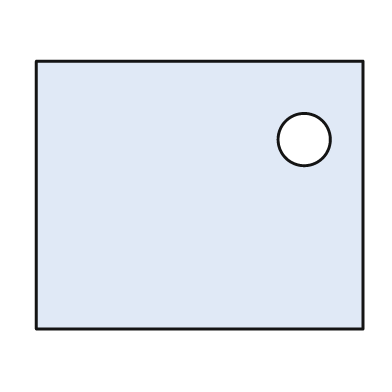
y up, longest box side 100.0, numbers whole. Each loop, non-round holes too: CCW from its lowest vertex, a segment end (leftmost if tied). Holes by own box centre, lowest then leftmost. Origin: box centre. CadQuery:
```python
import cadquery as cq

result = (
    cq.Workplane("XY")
    .moveTo(-50.0, -41.0)
    .lineTo(50.0, -41.0)
    .lineTo(50.0, 41.0)
    .lineTo(-50.0, 41.0)
    .close()
    .moveTo(32.0, 17.0)
    .circle(8.0)
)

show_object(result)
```